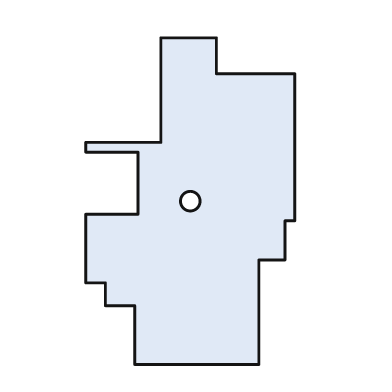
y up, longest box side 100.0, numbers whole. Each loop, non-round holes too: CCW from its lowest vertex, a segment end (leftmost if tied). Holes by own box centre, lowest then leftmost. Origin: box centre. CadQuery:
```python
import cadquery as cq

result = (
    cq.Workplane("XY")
    .moveTo(-17.0, -50.0)
    .lineTo(21.0, -50.0)
    .lineTo(21.0, -18.0)
    .lineTo(29.0, -18.0)
    .lineTo(29.0, -6.0)
    .lineTo(32.0, -6.0)
    .lineTo(32.0, 39.0)
    .lineTo(8.0, 39.0)
    .lineTo(8.0, 50.0)
    .lineTo(-9.0, 50.0)
    .lineTo(-9.0, 18.0)
    .lineTo(-32.0, 18.0)
    .lineTo(-32.0, 15.0)
    .lineTo(-16.0, 15.0)
    .lineTo(-16.0, -4.0)
    .lineTo(-32.0, -4.0)
    .lineTo(-32.0, -25.0)
    .lineTo(-26.0, -25.0)
    .lineTo(-26.0, -32.0)
    .lineTo(-17.0, -32.0)
    .close()
    .moveTo(0.0, 0.0)
    .circle(3.0)
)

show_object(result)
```